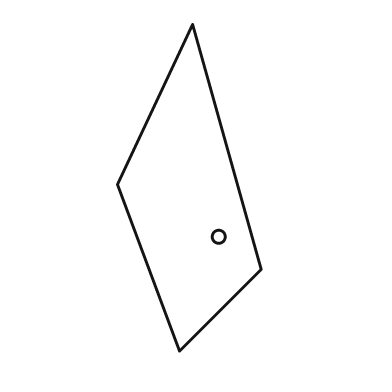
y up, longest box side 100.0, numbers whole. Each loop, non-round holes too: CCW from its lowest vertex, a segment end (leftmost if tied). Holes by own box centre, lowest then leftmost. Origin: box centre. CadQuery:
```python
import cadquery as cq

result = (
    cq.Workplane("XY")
    .moveTo(-3.0, -50.0)
    .lineTo(22.0, -25.0)
    .lineTo(1.0, 50.0)
    .lineTo(-22.0, 1.0)
    .close()
    .moveTo(9.0, -15.0)
    .circle(2.0)
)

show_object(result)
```